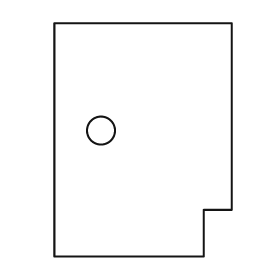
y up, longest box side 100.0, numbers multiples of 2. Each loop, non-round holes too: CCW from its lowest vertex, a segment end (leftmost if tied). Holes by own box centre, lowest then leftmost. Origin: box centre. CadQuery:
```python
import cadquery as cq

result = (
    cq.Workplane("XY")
    .moveTo(-38.0, -50.0)
    .lineTo(26.0, -50.0)
    .lineTo(26.0, -30.0)
    .lineTo(38.0, -30.0)
    .lineTo(38.0, 50.0)
    .lineTo(-38.0, 50.0)
    .close()
    .moveTo(-18.0, 4.0)
    .circle(6.0)
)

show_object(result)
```